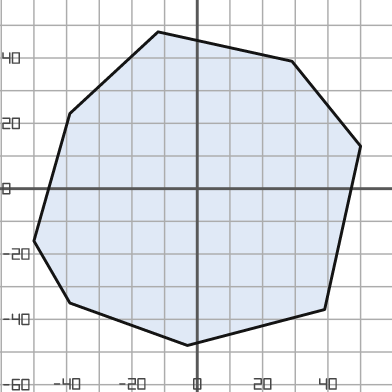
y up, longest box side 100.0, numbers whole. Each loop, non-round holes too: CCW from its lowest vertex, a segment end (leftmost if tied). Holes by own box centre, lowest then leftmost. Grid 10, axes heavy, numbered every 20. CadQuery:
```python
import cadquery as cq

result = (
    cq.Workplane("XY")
    .moveTo(-3.0, -48.0)
    .lineTo(39.0, -37.0)
    .lineTo(50.0, 13.0)
    .lineTo(29.0, 39.0)
    .lineTo(-12.0, 48.0)
    .lineTo(-39.0, 23.0)
    .lineTo(-50.0, -16.0)
    .lineTo(-39.0, -35.0)
    .close()
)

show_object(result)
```